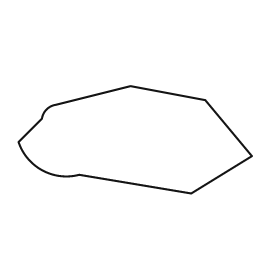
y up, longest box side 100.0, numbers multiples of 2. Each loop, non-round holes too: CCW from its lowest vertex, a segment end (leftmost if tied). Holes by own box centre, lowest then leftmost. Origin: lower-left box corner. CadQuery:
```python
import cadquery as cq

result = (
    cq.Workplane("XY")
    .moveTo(74.0, 0.0)
    .lineTo(100.0, 16.0)
    .lineTo(80.0, 40.0)
    .lineTo(48.0, 46.0)
    .lineTo(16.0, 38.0)
    .threePointArc((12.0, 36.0), (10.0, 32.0))
    .lineTo(0.0, 22.0)
    .threePointArc((10.0, 10.0), (26.0, 8.0))
    .close()
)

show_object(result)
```